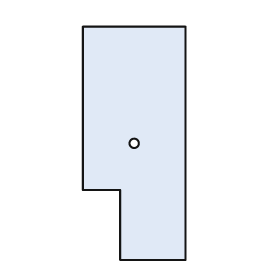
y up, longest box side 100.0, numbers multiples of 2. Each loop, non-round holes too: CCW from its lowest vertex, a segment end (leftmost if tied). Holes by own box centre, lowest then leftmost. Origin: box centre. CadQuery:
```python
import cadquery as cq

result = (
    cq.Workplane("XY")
    .moveTo(-6.0, -50.0)
    .lineTo(22.0, -50.0)
    .lineTo(22.0, 50.0)
    .lineTo(-22.0, 50.0)
    .lineTo(-22.0, -20.0)
    .lineTo(-6.0, -20.0)
    .close()
    .moveTo(0.0, 0.0)
    .circle(2.0)
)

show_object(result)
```